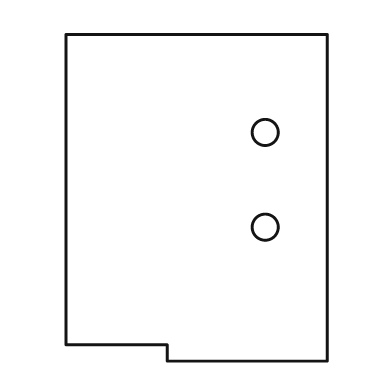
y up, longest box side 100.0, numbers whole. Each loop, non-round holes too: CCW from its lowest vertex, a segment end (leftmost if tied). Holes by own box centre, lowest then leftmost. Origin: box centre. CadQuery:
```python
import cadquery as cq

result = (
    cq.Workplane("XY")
    .moveTo(-9.0, -50.0)
    .lineTo(40.0, -50.0)
    .lineTo(40.0, 50.0)
    .lineTo(-40.0, 50.0)
    .lineTo(-40.0, -45.0)
    .lineTo(-9.0, -45.0)
    .close()
    .moveTo(21.0, -9.0)
    .circle(4.0)
    .moveTo(21.0, 20.0)
    .circle(4.0)
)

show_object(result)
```